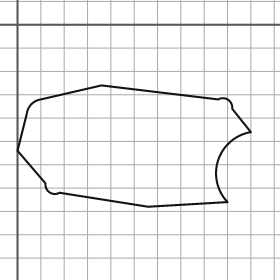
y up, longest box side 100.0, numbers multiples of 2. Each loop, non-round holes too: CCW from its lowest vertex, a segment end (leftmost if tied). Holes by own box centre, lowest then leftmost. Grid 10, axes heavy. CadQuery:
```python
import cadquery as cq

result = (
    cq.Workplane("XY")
    .moveTo(56.0, -78.0)
    .lineTo(90.0, -76.0)
    .threePointArc((86.0, -58.0), (100.0, -46.0))
    .lineTo(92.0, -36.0)
    .threePointArc((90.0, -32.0), (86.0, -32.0))
    .lineTo(36.0, -26.0)
    .lineTo(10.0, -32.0)
    .threePointArc((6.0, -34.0), (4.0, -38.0))
    .lineTo(0.0, -54.0)
    .lineTo(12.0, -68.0)
    .threePointArc((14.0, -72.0), (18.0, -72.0))
    .close()
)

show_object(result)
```